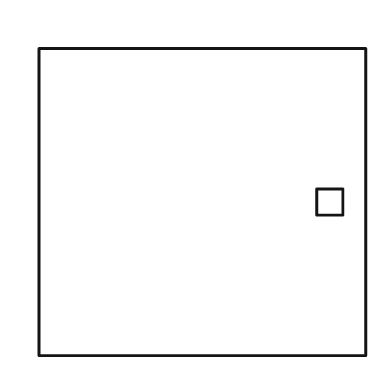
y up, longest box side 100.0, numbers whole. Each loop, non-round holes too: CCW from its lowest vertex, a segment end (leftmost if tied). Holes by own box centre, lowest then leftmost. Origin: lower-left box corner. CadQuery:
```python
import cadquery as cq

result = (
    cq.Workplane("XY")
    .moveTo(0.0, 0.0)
    .lineTo(100.0, 0.0)
    .lineTo(100.0, 94.0)
    .lineTo(0.0, 94.0)
    .close()
    .moveTo(85.0, 43.0)
    .lineTo(93.0, 43.0)
    .lineTo(93.0, 51.0)
    .lineTo(85.0, 51.0)
    .close()
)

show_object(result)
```